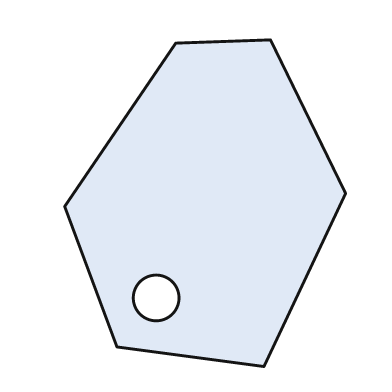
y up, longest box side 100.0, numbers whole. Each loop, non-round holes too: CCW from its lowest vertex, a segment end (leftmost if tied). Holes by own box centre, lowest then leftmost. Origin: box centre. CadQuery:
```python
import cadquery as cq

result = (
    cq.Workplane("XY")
    .moveTo(18.0, -50.0)
    .lineTo(43.0, 3.0)
    .lineTo(20.0, 50.0)
    .lineTo(-9.0, 49.0)
    .lineTo(-43.0, -1.0)
    .lineTo(-27.0, -44.0)
    .close()
    .moveTo(-15.0, -29.0)
    .circle(7.0)
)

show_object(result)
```